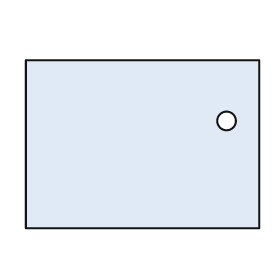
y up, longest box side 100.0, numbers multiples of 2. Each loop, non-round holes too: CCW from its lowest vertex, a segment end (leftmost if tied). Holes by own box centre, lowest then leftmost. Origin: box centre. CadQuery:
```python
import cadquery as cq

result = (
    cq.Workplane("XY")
    .moveTo(-50.0, -36.0)
    .lineTo(50.0, -36.0)
    .lineTo(50.0, 36.0)
    .lineTo(-50.0, 36.0)
    .close()
    .moveTo(36.0, 10.0)
    .circle(4.0)
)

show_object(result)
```